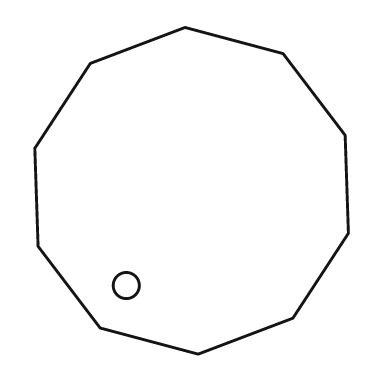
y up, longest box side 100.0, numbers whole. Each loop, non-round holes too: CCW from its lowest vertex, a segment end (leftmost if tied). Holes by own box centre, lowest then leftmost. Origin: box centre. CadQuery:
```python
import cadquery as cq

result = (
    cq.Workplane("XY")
    .moveTo(2.0, -50.0)
    .lineTo(31.0, -39.0)
    .lineTo(48.0, -13.0)
    .lineTo(47.0, 17.0)
    .lineTo(28.0, 42.0)
    .lineTo(-2.0, 50.0)
    .lineTo(-31.0, 39.0)
    .lineTo(-48.0, 13.0)
    .lineTo(-47.0, -17.0)
    .lineTo(-28.0, -42.0)
    .close()
    .moveTo(-20.0, -29.0)
    .circle(4.0)
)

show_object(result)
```